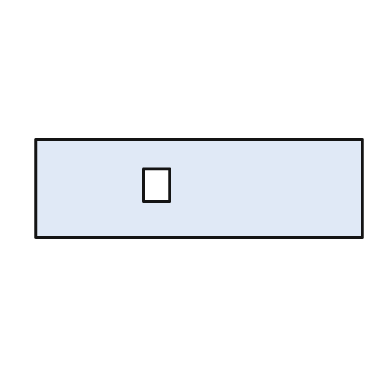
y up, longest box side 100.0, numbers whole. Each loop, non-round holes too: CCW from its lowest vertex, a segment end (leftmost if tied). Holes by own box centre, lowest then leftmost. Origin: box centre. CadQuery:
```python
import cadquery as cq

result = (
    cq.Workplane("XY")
    .moveTo(-50.0, -15.0)
    .lineTo(50.0, -15.0)
    .lineTo(50.0, 15.0)
    .lineTo(-50.0, 15.0)
    .close()
    .moveTo(-17.0, -4.0)
    .lineTo(-9.0, -4.0)
    .lineTo(-9.0, 6.0)
    .lineTo(-17.0, 6.0)
    .close()
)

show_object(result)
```